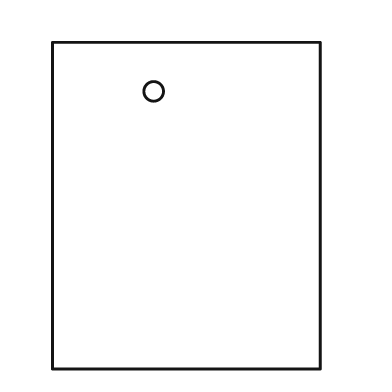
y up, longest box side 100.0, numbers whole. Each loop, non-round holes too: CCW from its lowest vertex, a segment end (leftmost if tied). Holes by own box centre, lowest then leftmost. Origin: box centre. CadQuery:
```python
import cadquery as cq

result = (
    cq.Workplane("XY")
    .moveTo(-41.0, -50.0)
    .lineTo(41.0, -50.0)
    .lineTo(41.0, 50.0)
    .lineTo(-41.0, 50.0)
    .close()
    .moveTo(-10.0, 35.0)
    .circle(3.0)
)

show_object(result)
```